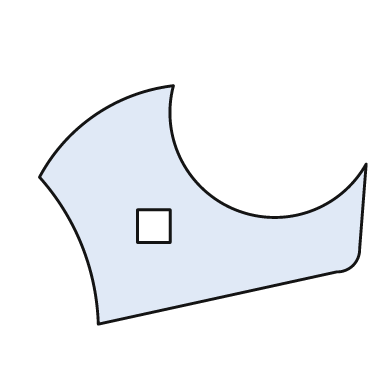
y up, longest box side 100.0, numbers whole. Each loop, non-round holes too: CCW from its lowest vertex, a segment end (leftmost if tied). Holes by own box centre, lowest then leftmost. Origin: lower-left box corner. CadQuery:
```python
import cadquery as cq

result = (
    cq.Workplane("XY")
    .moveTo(18.0, 0.0)
    .lineTo(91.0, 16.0)
    .threePointArc((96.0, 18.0), (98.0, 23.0))
    .lineTo(100.0, 49.0)
    .threePointArc((60.0, 35.0), (41.0, 73.0))
    .threePointArc((17.0, 64.0), (0.0, 45.0))
    .threePointArc((13.0, 24.0), (18.0, 0.0))
    .close()
    .moveTo(30.0, 25.0)
    .lineTo(40.0, 25.0)
    .lineTo(40.0, 35.0)
    .lineTo(30.0, 35.0)
    .close()
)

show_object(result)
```